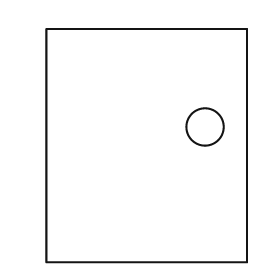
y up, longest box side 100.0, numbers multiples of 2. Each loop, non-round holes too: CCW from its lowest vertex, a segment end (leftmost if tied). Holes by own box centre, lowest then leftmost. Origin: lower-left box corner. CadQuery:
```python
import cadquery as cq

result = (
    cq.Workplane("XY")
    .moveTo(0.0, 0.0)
    .lineTo(86.0, 0.0)
    .lineTo(86.0, 100.0)
    .lineTo(0.0, 100.0)
    .close()
    .moveTo(68.0, 58.0)
    .circle(8.0)
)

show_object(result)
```